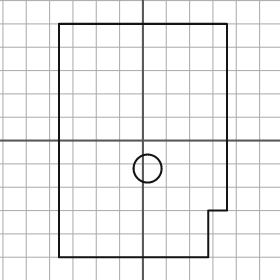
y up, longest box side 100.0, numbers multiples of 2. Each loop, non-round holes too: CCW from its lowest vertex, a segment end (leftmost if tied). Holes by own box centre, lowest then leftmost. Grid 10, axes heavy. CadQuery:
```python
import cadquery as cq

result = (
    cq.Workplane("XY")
    .moveTo(-36.0, -50.0)
    .lineTo(28.0, -50.0)
    .lineTo(28.0, -30.0)
    .lineTo(36.0, -30.0)
    .lineTo(36.0, 50.0)
    .lineTo(-36.0, 50.0)
    .close()
    .moveTo(2.0, -12.0)
    .circle(6.0)
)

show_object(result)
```